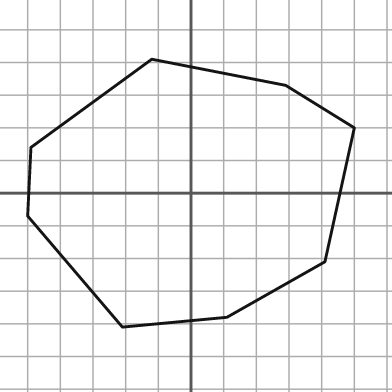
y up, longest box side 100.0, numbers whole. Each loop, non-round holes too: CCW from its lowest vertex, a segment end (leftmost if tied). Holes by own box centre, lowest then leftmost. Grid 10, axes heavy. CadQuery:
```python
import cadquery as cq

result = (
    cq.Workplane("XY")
    .moveTo(-21.0, -41.0)
    .lineTo(11.0, -38.0)
    .lineTo(41.0, -21.0)
    .lineTo(50.0, 20.0)
    .lineTo(29.0, 33.0)
    .lineTo(-12.0, 41.0)
    .lineTo(-49.0, 14.0)
    .lineTo(-50.0, -7.0)
    .close()
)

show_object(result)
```